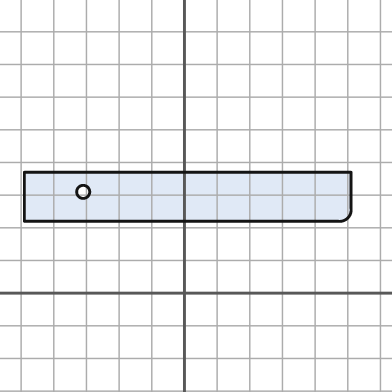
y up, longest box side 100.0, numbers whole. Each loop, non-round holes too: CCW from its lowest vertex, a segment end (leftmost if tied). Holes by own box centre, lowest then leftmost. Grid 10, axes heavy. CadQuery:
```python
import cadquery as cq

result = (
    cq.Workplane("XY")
    .moveTo(-49.0, 22.0)
    .lineTo(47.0, 22.0)
    .threePointArc((50.0, 23.0), (51.0, 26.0))
    .lineTo(51.0, 37.0)
    .lineTo(-49.0, 37.0)
    .close()
    .moveTo(-31.0, 31.0)
    .circle(2.0)
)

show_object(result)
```